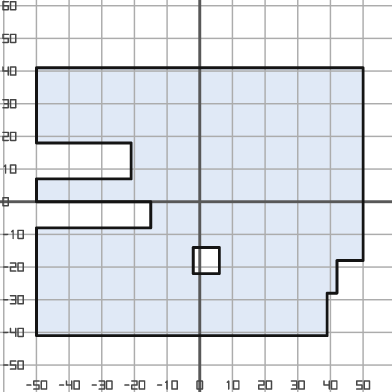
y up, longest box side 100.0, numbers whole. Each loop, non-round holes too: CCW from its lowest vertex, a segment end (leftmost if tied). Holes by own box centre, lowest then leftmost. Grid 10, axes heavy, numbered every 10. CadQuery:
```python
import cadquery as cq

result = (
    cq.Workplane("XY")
    .moveTo(-50.0, -41.0)
    .lineTo(39.0, -41.0)
    .lineTo(39.0, -28.0)
    .lineTo(42.0, -28.0)
    .lineTo(42.0, -18.0)
    .lineTo(50.0, -18.0)
    .lineTo(50.0, 41.0)
    .lineTo(-50.0, 41.0)
    .lineTo(-50.0, 18.0)
    .lineTo(-21.0, 18.0)
    .lineTo(-21.0, 7.0)
    .lineTo(-50.0, 7.0)
    .lineTo(-50.0, 0.0)
    .lineTo(-15.0, 0.0)
    .lineTo(-15.0, -8.0)
    .lineTo(-50.0, -8.0)
    .close()
    .moveTo(-2.0, -22.0)
    .lineTo(6.0, -22.0)
    .lineTo(6.0, -14.0)
    .lineTo(-2.0, -14.0)
    .close()
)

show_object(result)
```